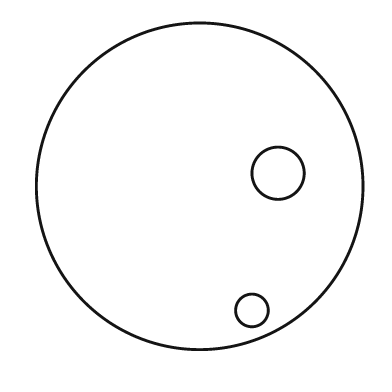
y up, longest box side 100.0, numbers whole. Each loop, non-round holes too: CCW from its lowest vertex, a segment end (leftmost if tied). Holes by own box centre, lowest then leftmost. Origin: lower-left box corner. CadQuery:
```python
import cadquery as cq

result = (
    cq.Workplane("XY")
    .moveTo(50.0, 50.0)
    .circle(50.0)
    .moveTo(66.0, 12.0)
    .circle(5.0)
    .moveTo(74.0, 54.0)
    .circle(8.0)
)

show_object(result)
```